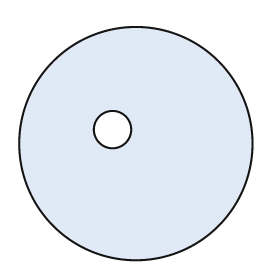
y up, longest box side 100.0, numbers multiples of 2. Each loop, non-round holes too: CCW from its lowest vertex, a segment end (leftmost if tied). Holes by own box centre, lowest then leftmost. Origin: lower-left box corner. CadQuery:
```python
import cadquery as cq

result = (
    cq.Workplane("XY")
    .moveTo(50.0, 50.0)
    .circle(50.0)
    .moveTo(40.0, 56.0)
    .circle(8.0)
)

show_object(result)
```